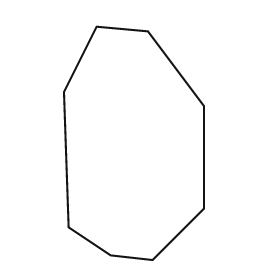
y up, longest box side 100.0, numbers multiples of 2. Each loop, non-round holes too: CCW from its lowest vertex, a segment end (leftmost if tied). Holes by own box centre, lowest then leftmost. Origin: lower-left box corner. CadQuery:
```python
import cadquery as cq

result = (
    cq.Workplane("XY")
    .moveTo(38.0, 0.0)
    .lineTo(60.0, 22.0)
    .lineTo(60.0, 66.0)
    .lineTo(36.0, 98.0)
    .lineTo(14.0, 100.0)
    .lineTo(0.0, 72.0)
    .lineTo(2.0, 14.0)
    .lineTo(20.0, 2.0)
    .close()
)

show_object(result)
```